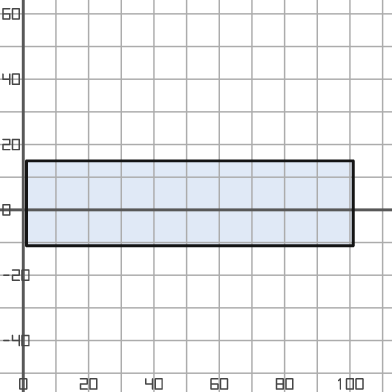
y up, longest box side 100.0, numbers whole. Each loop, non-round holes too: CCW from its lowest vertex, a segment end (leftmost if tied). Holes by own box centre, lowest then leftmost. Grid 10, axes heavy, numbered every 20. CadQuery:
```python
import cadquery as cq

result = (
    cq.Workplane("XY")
    .moveTo(1.0, -11.0)
    .lineTo(101.0, -11.0)
    .lineTo(101.0, 15.0)
    .lineTo(1.0, 15.0)
    .close()
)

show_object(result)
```